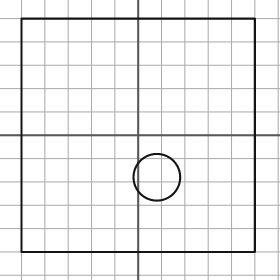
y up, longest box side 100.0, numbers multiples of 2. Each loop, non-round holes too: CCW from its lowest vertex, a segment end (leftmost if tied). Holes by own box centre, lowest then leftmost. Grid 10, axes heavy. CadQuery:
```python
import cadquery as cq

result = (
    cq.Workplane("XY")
    .moveTo(-50.0, -50.0)
    .lineTo(50.0, -50.0)
    .lineTo(50.0, 50.0)
    .lineTo(-50.0, 50.0)
    .close()
    .moveTo(8.0, -18.0)
    .circle(10.0)
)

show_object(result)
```